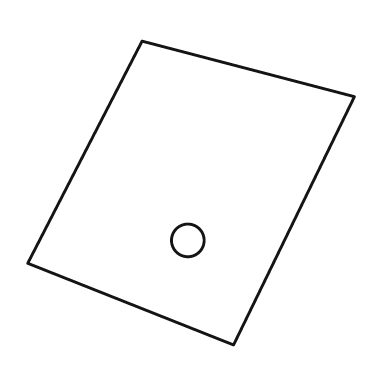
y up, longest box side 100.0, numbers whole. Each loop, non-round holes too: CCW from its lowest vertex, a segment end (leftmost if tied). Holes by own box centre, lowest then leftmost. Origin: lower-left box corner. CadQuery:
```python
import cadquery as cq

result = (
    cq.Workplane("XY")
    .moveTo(63.0, 0.0)
    .lineTo(100.0, 76.0)
    .lineTo(35.0, 93.0)
    .lineTo(0.0, 25.0)
    .close()
    .moveTo(49.0, 32.0)
    .circle(5.0)
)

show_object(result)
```